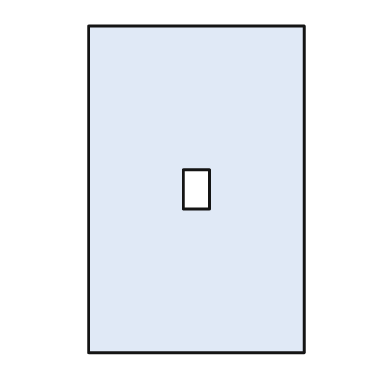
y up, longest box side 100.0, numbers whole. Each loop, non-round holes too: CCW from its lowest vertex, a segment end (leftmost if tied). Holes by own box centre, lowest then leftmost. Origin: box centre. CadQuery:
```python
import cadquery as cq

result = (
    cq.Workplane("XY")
    .moveTo(-33.0, -50.0)
    .lineTo(33.0, -50.0)
    .lineTo(33.0, 50.0)
    .lineTo(-33.0, 50.0)
    .close()
    .moveTo(-4.0, -6.0)
    .lineTo(4.0, -6.0)
    .lineTo(4.0, 6.0)
    .lineTo(-4.0, 6.0)
    .close()
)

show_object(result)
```